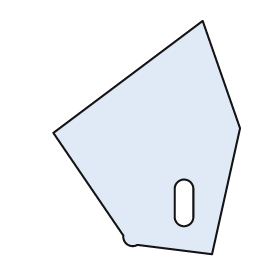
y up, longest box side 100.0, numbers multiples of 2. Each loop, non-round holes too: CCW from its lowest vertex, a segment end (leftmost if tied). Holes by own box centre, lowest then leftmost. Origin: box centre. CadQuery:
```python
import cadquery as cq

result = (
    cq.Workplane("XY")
    .moveTo(28.0, -50.0)
    .lineTo(40.0, 4.0)
    .lineTo(24.0, 50.0)
    .lineTo(-40.0, 2.0)
    .lineTo(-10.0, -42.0)
    .threePointArc((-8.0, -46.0), (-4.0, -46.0))
    .close()
    .moveTo(12.0, -34.0)
    .threePointArc((16.0, -38.0), (20.0, -34.0))
    .lineTo(20.0, -22.0)
    .threePointArc((16.0, -18.0), (12.0, -22.0))
    .close()
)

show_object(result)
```